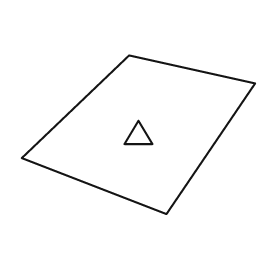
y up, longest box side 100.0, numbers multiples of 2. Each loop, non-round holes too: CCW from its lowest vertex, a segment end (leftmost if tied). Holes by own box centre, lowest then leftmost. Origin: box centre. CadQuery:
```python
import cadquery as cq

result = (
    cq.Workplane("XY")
    .moveTo(12.0, -34.0)
    .lineTo(50.0, 22.0)
    .lineTo(-4.0, 34.0)
    .lineTo(-50.0, -10.0)
    .close()
    .moveTo(-6.0, -4.0)
    .lineTo(6.0, -4.0)
    .lineTo(0.0, 6.0)
    .close()
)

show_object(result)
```